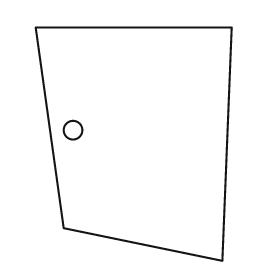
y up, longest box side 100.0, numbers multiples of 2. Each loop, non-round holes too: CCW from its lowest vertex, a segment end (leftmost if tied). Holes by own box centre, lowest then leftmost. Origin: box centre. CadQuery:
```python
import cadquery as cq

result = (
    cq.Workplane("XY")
    .moveTo(38.0, -50.0)
    .lineTo(42.0, 50.0)
    .lineTo(-42.0, 50.0)
    .lineTo(-30.0, -36.0)
    .close()
    .moveTo(-26.0, 6.0)
    .circle(4.0)
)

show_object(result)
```